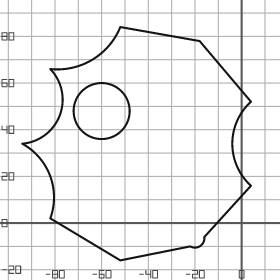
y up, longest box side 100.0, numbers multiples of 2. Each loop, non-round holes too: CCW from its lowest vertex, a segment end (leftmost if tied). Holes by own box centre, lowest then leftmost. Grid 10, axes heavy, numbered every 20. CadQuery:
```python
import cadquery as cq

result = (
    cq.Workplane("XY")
    .moveTo(-52.0, -16.0)
    .lineTo(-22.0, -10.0)
    .threePointArc((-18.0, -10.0), (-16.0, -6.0))
    .lineTo(4.0, 16.0)
    .threePointArc((-4.0, 34.0), (4.0, 52.0))
    .lineTo(-18.0, 78.0)
    .lineTo(-52.0, 84.0)
    .threePointArc((-64.0, 70.0), (-82.0, 66.0))
    .threePointArc((-78.0, 46.0), (-94.0, 34.0))
    .threePointArc((-82.0, 20.0), (-82.0, 2.0))
    .close()
    .moveTo(-60.0, 48.0)
    .circle(12.0)
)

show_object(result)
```